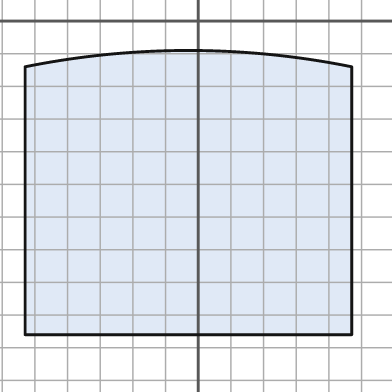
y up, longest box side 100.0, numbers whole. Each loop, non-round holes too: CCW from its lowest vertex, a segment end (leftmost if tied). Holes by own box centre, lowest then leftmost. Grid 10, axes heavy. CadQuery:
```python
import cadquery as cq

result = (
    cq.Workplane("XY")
    .moveTo(-53.0, -96.0)
    .lineTo(47.0, -96.0)
    .lineTo(47.0, -14.0)
    .threePointArc((-3.0, -9.0), (-53.0, -14.0))
    .close()
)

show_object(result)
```